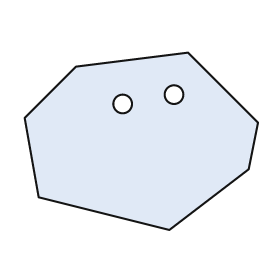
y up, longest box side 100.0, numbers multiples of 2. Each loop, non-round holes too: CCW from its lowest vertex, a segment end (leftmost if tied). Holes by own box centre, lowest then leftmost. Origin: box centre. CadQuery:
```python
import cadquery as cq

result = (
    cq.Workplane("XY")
    .moveTo(12.0, -38.0)
    .lineTo(46.0, -12.0)
    .lineTo(50.0, 8.0)
    .lineTo(20.0, 38.0)
    .lineTo(-28.0, 32.0)
    .lineTo(-50.0, 10.0)
    .lineTo(-44.0, -24.0)
    .close()
    .moveTo(-8.0, 16.0)
    .circle(4.0)
    .moveTo(14.0, 20.0)
    .circle(4.0)
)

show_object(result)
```